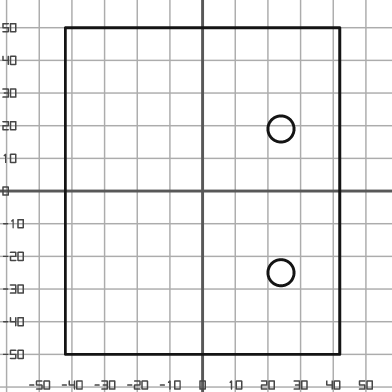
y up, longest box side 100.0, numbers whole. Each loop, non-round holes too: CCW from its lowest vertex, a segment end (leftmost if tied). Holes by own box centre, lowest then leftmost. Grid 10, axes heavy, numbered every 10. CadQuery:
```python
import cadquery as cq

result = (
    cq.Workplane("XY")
    .moveTo(-42.0, -50.0)
    .lineTo(42.0, -50.0)
    .lineTo(42.0, 50.0)
    .lineTo(-42.0, 50.0)
    .close()
    .moveTo(24.0, -25.0)
    .circle(4.0)
    .moveTo(24.0, 19.0)
    .circle(4.0)
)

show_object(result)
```